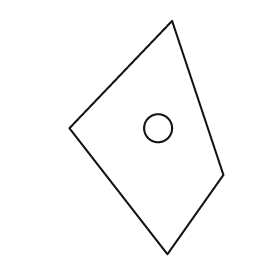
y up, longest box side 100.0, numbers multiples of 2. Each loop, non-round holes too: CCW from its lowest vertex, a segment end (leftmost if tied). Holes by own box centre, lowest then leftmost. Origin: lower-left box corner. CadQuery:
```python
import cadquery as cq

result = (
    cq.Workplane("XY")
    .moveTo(42.0, 0.0)
    .lineTo(66.0, 34.0)
    .lineTo(44.0, 100.0)
    .lineTo(0.0, 54.0)
    .close()
    .moveTo(38.0, 54.0)
    .circle(6.0)
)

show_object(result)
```